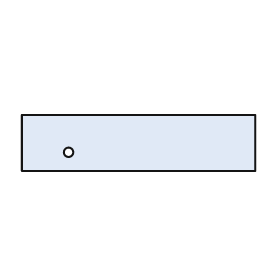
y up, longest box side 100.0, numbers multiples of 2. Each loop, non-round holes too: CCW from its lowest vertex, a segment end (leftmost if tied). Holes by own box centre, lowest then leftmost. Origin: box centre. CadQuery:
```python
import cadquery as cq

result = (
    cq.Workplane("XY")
    .moveTo(-50.0, -12.0)
    .lineTo(50.0, -12.0)
    .lineTo(50.0, 12.0)
    .lineTo(-50.0, 12.0)
    .close()
    .moveTo(-30.0, -4.0)
    .circle(2.0)
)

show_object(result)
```